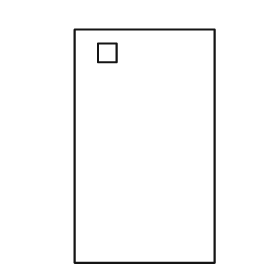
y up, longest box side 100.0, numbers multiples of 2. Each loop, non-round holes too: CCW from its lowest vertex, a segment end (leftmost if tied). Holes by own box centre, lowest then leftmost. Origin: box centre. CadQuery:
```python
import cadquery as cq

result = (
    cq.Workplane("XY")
    .moveTo(-30.0, -50.0)
    .lineTo(30.0, -50.0)
    .lineTo(30.0, 50.0)
    .lineTo(-30.0, 50.0)
    .close()
    .moveTo(-20.0, 36.0)
    .lineTo(-12.0, 36.0)
    .lineTo(-12.0, 44.0)
    .lineTo(-20.0, 44.0)
    .close()
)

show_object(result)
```